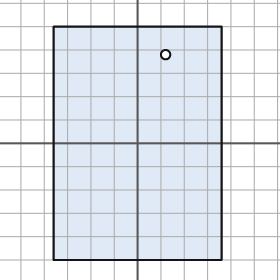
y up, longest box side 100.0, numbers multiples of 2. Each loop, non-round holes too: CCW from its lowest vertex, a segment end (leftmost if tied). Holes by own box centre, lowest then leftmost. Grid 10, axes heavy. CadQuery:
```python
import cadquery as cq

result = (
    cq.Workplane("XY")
    .moveTo(-36.0, -50.0)
    .lineTo(36.0, -50.0)
    .lineTo(36.0, 50.0)
    .lineTo(-36.0, 50.0)
    .close()
    .moveTo(12.0, 38.0)
    .circle(2.0)
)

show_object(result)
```